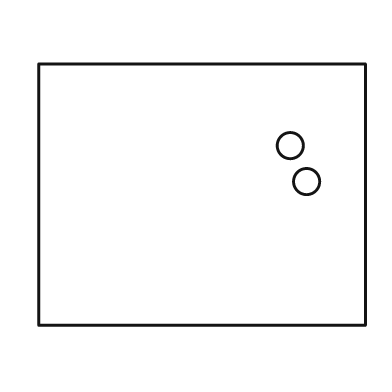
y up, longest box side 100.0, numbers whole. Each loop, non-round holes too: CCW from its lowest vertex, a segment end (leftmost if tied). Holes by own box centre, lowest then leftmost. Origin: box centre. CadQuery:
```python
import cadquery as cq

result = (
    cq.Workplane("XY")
    .moveTo(-50.0, -40.0)
    .lineTo(50.0, -40.0)
    .lineTo(50.0, 40.0)
    .lineTo(-50.0, 40.0)
    .close()
    .moveTo(32.0, 4.0)
    .circle(4.0)
    .moveTo(27.0, 15.0)
    .circle(4.0)
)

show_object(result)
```